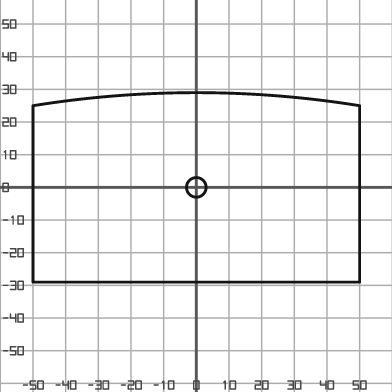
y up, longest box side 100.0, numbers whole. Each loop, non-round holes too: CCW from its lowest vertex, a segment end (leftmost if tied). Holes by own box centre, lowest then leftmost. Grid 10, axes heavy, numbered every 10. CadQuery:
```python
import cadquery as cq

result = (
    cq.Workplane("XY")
    .moveTo(-50.0, -29.0)
    .lineTo(50.0, -29.0)
    .lineTo(50.0, 25.0)
    .threePointArc((0.0, 29.0), (-50.0, 25.0))
    .close()
    .moveTo(0.0, 0.0)
    .circle(3.0)
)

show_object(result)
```